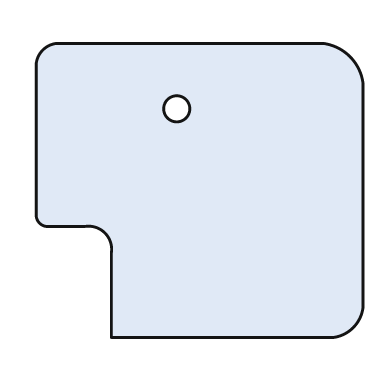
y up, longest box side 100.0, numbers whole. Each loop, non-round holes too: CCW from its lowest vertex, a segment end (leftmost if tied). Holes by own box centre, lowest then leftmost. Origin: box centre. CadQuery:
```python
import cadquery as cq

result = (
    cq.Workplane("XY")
    .moveTo(-27.0, -45.0)
    .lineTo(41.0, -45.0)
    .threePointArc((47.0, -42.0), (50.0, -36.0))
    .lineTo(50.0, 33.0)
    .threePointArc((46.0, 41.0), (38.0, 45.0))
    .lineTo(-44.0, 45.0)
    .threePointArc((-48.0, 43.0), (-50.0, 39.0))
    .lineTo(-50.0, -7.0)
    .threePointArc((-49.0, -10.0), (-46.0, -11.0))
    .lineTo(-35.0, -11.0)
    .threePointArc((-29.0, -13.0), (-27.0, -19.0))
    .close()
    .moveTo(-7.0, 25.0)
    .circle(4.0)
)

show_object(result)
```